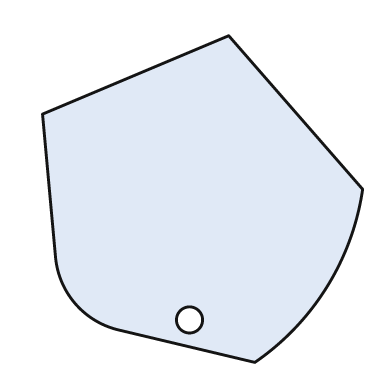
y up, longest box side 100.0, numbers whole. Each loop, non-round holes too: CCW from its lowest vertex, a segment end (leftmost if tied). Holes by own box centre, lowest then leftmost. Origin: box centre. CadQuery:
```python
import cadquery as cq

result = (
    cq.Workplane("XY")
    .moveTo(16.0, -50.0)
    .threePointArc((38.0, -27.0), (49.0, 3.0))
    .lineTo(8.0, 50.0)
    .lineTo(-49.0, 26.0)
    .lineTo(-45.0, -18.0)
    .threePointArc((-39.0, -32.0), (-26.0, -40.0))
    .close()
    .moveTo(-4.0, -37.0)
    .circle(4.0)
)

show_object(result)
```